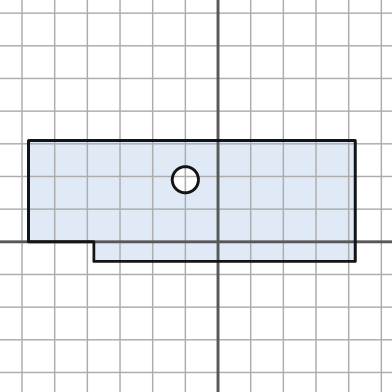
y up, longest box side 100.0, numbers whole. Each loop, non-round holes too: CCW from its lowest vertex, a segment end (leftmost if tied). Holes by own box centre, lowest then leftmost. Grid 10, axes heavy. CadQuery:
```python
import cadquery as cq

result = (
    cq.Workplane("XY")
    .moveTo(-38.0, -6.0)
    .lineTo(42.0, -6.0)
    .lineTo(42.0, 31.0)
    .lineTo(-58.0, 31.0)
    .lineTo(-58.0, 0.0)
    .lineTo(-38.0, 0.0)
    .close()
    .moveTo(-10.0, 19.0)
    .circle(4.0)
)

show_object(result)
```